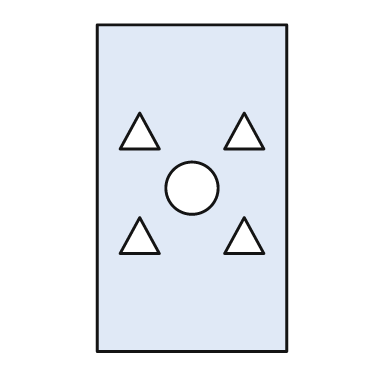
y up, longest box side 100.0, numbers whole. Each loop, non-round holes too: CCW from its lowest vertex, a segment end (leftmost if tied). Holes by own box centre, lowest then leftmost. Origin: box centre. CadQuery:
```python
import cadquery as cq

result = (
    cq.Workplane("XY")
    .moveTo(-29.0, -50.0)
    .lineTo(29.0, -50.0)
    .lineTo(29.0, 50.0)
    .lineTo(-29.0, 50.0)
    .close()
    .moveTo(-22.0, -20.0)
    .lineTo(-10.0, -20.0)
    .lineTo(-16.0, -9.0)
    .close()
    .moveTo(10.0, -20.0)
    .lineTo(22.0, -20.0)
    .lineTo(16.0, -9.0)
    .close()
    .moveTo(0.0, 0.0)
    .circle(8.0)
    .moveTo(-22.0, 12.0)
    .lineTo(-10.0, 12.0)
    .lineTo(-16.0, 23.0)
    .close()
    .moveTo(10.0, 12.0)
    .lineTo(22.0, 12.0)
    .lineTo(16.0, 23.0)
    .close()
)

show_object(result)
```